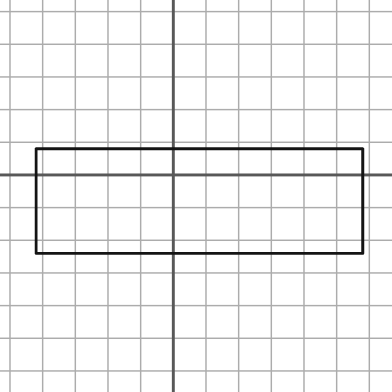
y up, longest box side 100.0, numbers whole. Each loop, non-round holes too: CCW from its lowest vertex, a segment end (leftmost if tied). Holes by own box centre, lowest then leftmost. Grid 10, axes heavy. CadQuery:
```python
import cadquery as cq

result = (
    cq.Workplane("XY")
    .moveTo(-42.0, -24.0)
    .lineTo(58.0, -24.0)
    .lineTo(58.0, 8.0)
    .lineTo(-42.0, 8.0)
    .close()
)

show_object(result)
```